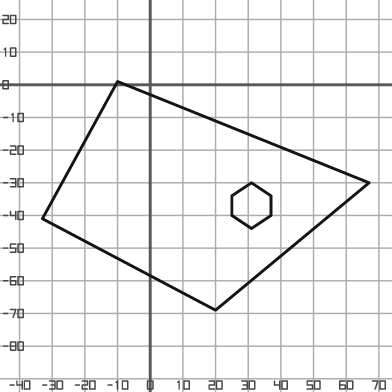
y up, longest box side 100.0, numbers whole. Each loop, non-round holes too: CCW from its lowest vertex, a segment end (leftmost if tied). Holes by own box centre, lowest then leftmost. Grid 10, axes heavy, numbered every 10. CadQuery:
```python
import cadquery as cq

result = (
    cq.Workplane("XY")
    .moveTo(20.0, -69.0)
    .lineTo(67.0, -30.0)
    .lineTo(-10.0, 1.0)
    .lineTo(-33.0, -41.0)
    .close()
    .moveTo(31.0, -44.0)
    .lineTo(37.0, -40.0)
    .lineTo(37.0, -34.0)
    .lineTo(31.0, -30.0)
    .lineTo(25.0, -34.0)
    .lineTo(25.0, -40.0)
    .close()
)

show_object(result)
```